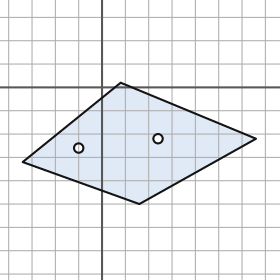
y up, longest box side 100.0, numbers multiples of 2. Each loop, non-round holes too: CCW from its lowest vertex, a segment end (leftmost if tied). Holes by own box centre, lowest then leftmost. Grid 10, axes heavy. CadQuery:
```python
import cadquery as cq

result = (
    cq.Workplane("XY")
    .moveTo(16.0, -50.0)
    .lineTo(66.0, -22.0)
    .lineTo(8.0, 2.0)
    .lineTo(-34.0, -32.0)
    .close()
    .moveTo(-10.0, -26.0)
    .circle(2.0)
    .moveTo(24.0, -22.0)
    .circle(2.0)
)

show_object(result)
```